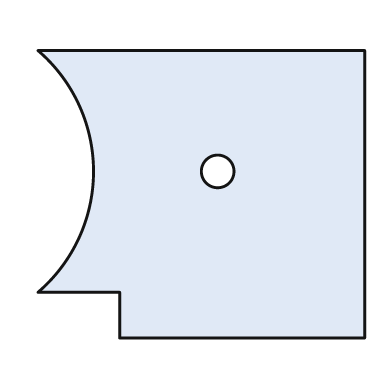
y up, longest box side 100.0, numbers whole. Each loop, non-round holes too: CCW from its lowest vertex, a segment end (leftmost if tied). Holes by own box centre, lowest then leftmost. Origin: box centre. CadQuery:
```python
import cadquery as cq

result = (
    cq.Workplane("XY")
    .moveTo(-25.0, -44.0)
    .lineTo(50.0, -44.0)
    .lineTo(50.0, 44.0)
    .lineTo(-50.0, 44.0)
    .threePointArc((-33.0, 7.0), (-50.0, -30.0))
    .lineTo(-25.0, -30.0)
    .close()
    .moveTo(5.0, 7.0)
    .circle(5.0)
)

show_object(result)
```